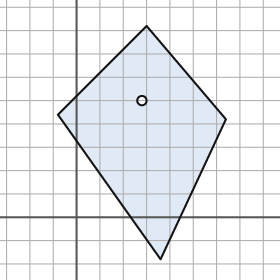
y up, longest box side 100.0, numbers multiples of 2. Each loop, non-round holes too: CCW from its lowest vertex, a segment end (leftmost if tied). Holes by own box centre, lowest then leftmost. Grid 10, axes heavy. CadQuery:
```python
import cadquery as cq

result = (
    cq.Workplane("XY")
    .moveTo(36.0, -18.0)
    .lineTo(64.0, 42.0)
    .lineTo(30.0, 82.0)
    .lineTo(-8.0, 44.0)
    .close()
    .moveTo(28.0, 50.0)
    .circle(2.0)
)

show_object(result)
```